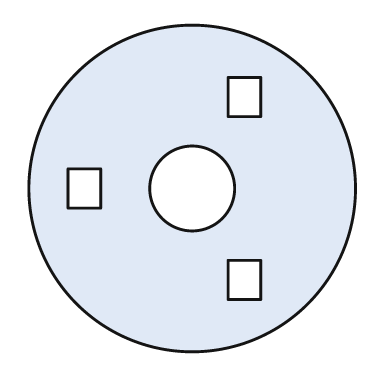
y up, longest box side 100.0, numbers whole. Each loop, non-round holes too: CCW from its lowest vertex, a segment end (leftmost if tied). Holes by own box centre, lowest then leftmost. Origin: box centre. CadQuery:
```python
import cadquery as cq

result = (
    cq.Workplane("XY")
    .moveTo(0.0, 0.0)
    .circle(50.0)
    .moveTo(11.0, -34.0)
    .lineTo(21.0, -34.0)
    .lineTo(21.0, -22.0)
    .lineTo(11.0, -22.0)
    .close()
    .moveTo(-38.0, -6.0)
    .lineTo(-28.0, -6.0)
    .lineTo(-28.0, 6.0)
    .lineTo(-38.0, 6.0)
    .close()
    .moveTo(0.0, 0.0)
    .circle(13.0)
    .moveTo(11.0, 22.0)
    .lineTo(21.0, 22.0)
    .lineTo(21.0, 34.0)
    .lineTo(11.0, 34.0)
    .close()
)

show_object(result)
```